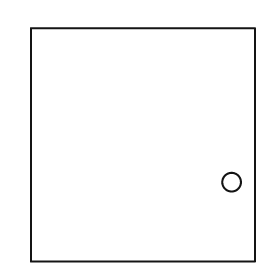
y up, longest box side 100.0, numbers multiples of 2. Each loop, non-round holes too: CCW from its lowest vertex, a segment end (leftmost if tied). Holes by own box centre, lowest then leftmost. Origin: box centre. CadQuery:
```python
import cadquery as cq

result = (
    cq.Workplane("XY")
    .moveTo(-48.0, -50.0)
    .lineTo(48.0, -50.0)
    .lineTo(48.0, 50.0)
    .lineTo(-48.0, 50.0)
    .close()
    .moveTo(38.0, -16.0)
    .circle(4.0)
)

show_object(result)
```